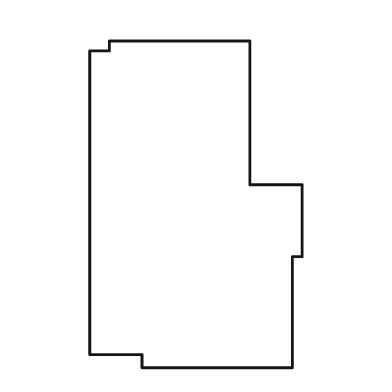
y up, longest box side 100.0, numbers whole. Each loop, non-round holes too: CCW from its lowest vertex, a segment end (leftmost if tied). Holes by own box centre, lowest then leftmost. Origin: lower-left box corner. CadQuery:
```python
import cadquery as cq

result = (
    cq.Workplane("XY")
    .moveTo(16.0, 0.0)
    .lineTo(62.0, 0.0)
    .lineTo(62.0, 34.0)
    .lineTo(65.0, 34.0)
    .lineTo(65.0, 56.0)
    .lineTo(49.0, 56.0)
    .lineTo(49.0, 100.0)
    .lineTo(6.0, 100.0)
    .lineTo(6.0, 97.0)
    .lineTo(0.0, 97.0)
    .lineTo(0.0, 4.0)
    .lineTo(16.0, 4.0)
    .close()
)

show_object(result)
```